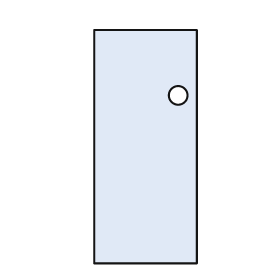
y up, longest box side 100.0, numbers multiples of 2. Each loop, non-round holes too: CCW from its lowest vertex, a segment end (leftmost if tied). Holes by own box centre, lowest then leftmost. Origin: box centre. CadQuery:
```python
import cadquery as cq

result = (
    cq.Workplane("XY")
    .moveTo(-22.0, -50.0)
    .lineTo(22.0, -50.0)
    .lineTo(22.0, 50.0)
    .lineTo(-22.0, 50.0)
    .close()
    .moveTo(14.0, 22.0)
    .circle(4.0)
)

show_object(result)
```